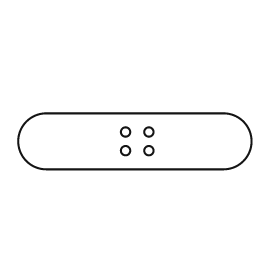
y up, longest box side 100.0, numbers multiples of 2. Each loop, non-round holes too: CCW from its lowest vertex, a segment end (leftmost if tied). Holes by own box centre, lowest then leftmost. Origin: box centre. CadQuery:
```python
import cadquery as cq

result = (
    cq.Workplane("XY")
    .moveTo(-38.0, -12.0)
    .lineTo(38.0, -12.0)
    .threePointArc((50.0, 0.0), (38.0, 12.0))
    .lineTo(-38.0, 12.0)
    .threePointArc((-50.0, 0.0), (-38.0, -12.0))
    .close()
    .moveTo(-4.0, -4.0)
    .circle(2.0)
    .moveTo(6.0, -4.0)
    .circle(2.0)
    .moveTo(-4.0, 4.0)
    .circle(2.0)
    .moveTo(6.0, 4.0)
    .circle(2.0)
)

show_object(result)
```